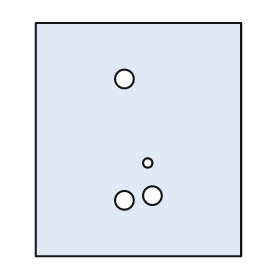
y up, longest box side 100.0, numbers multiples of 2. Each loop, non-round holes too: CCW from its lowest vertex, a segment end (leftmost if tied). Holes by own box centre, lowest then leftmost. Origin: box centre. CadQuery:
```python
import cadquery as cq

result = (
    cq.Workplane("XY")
    .moveTo(-44.0, -50.0)
    .lineTo(44.0, -50.0)
    .lineTo(44.0, 50.0)
    .lineTo(-44.0, 50.0)
    .close()
    .moveTo(-6.0, -26.0)
    .circle(4.0)
    .moveTo(6.0, -24.0)
    .circle(4.0)
    .moveTo(4.0, -10.0)
    .circle(2.0)
    .moveTo(-6.0, 26.0)
    .circle(4.0)
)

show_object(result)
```